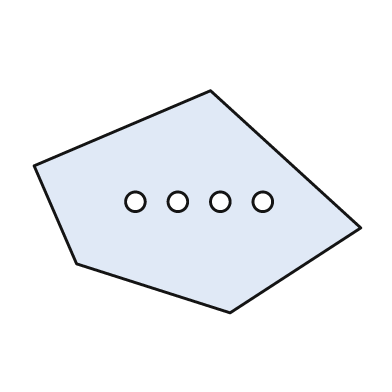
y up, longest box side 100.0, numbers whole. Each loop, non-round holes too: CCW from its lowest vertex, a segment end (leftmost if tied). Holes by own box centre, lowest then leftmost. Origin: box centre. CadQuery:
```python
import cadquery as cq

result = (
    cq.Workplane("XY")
    .moveTo(10.0, -34.0)
    .lineTo(50.0, -8.0)
    .lineTo(4.0, 34.0)
    .lineTo(-50.0, 11.0)
    .lineTo(-37.0, -19.0)
    .close()
    .moveTo(-19.0, 0.0)
    .circle(3.0)
    .moveTo(-6.0, 0.0)
    .circle(3.0)
    .moveTo(7.0, 0.0)
    .circle(3.0)
    .moveTo(20.0, 0.0)
    .circle(3.0)
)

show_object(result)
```